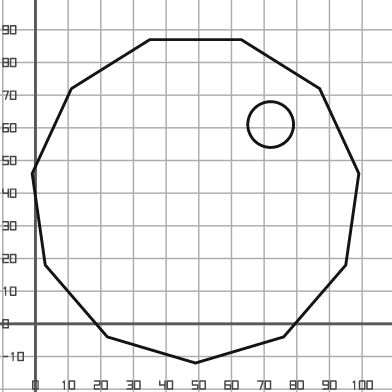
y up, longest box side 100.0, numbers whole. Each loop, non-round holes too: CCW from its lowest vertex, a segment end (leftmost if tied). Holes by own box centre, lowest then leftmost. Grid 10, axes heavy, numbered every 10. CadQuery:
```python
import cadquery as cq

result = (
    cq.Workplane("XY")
    .moveTo(49.0, -12.0)
    .lineTo(76.0, -4.0)
    .lineTo(95.0, 18.0)
    .lineTo(99.0, 46.0)
    .lineTo(87.0, 72.0)
    .lineTo(63.0, 87.0)
    .lineTo(35.0, 87.0)
    .lineTo(11.0, 72.0)
    .lineTo(-1.0, 46.0)
    .lineTo(3.0, 18.0)
    .lineTo(22.0, -4.0)
    .close()
    .moveTo(72.0, 61.0)
    .circle(7.0)
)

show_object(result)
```